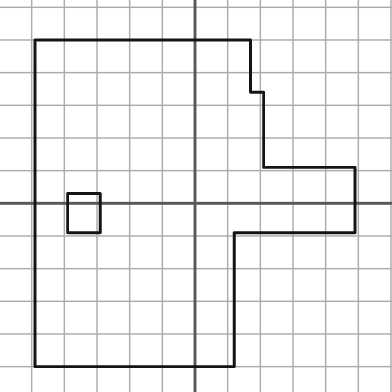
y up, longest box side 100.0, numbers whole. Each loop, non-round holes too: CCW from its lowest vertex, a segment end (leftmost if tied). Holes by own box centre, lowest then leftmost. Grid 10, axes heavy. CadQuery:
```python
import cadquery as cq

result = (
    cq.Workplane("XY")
    .moveTo(-49.0, -50.0)
    .lineTo(12.0, -50.0)
    .lineTo(12.0, -9.0)
    .lineTo(49.0, -9.0)
    .lineTo(49.0, 11.0)
    .lineTo(21.0, 11.0)
    .lineTo(21.0, 34.0)
    .lineTo(17.0, 34.0)
    .lineTo(17.0, 50.0)
    .lineTo(-49.0, 50.0)
    .close()
    .moveTo(-39.0, -9.0)
    .lineTo(-29.0, -9.0)
    .lineTo(-29.0, 3.0)
    .lineTo(-39.0, 3.0)
    .close()
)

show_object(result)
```